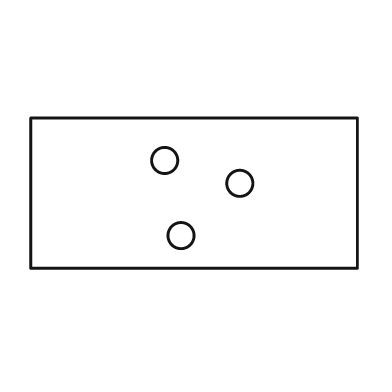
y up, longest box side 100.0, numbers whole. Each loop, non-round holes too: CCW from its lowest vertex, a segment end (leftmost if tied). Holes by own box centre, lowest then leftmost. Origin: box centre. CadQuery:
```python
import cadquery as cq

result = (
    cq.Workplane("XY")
    .moveTo(-50.0, -23.0)
    .lineTo(50.0, -23.0)
    .lineTo(50.0, 23.0)
    .lineTo(-50.0, 23.0)
    .close()
    .moveTo(-4.0, -13.0)
    .circle(4.0)
    .moveTo(14.0, 3.0)
    .circle(4.0)
    .moveTo(-9.0, 10.0)
    .circle(4.0)
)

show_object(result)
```